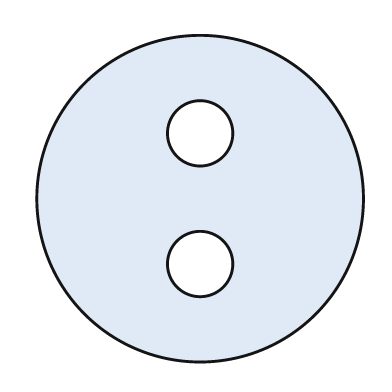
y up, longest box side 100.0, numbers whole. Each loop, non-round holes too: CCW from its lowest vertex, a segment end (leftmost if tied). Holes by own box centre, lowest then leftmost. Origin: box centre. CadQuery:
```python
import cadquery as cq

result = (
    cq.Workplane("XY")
    .moveTo(0.0, 0.0)
    .circle(50.0)
    .moveTo(0.0, -20.0)
    .circle(10.0)
    .moveTo(0.0, 20.0)
    .circle(10.0)
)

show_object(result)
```